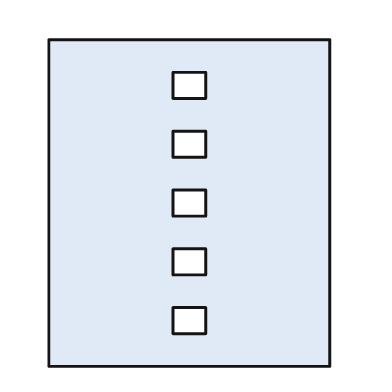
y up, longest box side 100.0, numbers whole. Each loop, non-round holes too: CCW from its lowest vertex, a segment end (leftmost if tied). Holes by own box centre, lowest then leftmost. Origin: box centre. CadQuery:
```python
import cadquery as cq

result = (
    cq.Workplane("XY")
    .moveTo(-43.0, -50.0)
    .lineTo(43.0, -50.0)
    .lineTo(43.0, 50.0)
    .lineTo(-43.0, 50.0)
    .close()
    .moveTo(-5.0, -40.0)
    .lineTo(5.0, -40.0)
    .lineTo(5.0, -32.0)
    .lineTo(-5.0, -32.0)
    .close()
    .moveTo(-5.0, -22.0)
    .lineTo(5.0, -22.0)
    .lineTo(5.0, -14.0)
    .lineTo(-5.0, -14.0)
    .close()
    .moveTo(-5.0, -4.0)
    .lineTo(5.0, -4.0)
    .lineTo(5.0, 4.0)
    .lineTo(-5.0, 4.0)
    .close()
    .moveTo(-5.0, 14.0)
    .lineTo(5.0, 14.0)
    .lineTo(5.0, 22.0)
    .lineTo(-5.0, 22.0)
    .close()
    .moveTo(-5.0, 32.0)
    .lineTo(5.0, 32.0)
    .lineTo(5.0, 40.0)
    .lineTo(-5.0, 40.0)
    .close()
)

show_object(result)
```